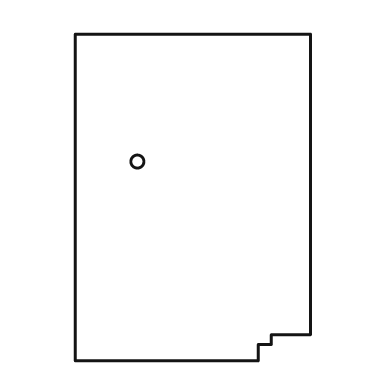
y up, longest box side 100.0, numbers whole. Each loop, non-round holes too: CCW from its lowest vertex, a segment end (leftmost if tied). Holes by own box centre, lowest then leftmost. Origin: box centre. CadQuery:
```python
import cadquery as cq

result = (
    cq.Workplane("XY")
    .moveTo(-36.0, -50.0)
    .lineTo(20.0, -50.0)
    .lineTo(20.0, -45.0)
    .lineTo(24.0, -45.0)
    .lineTo(24.0, -42.0)
    .lineTo(36.0, -42.0)
    .lineTo(36.0, 50.0)
    .lineTo(-36.0, 50.0)
    .close()
    .moveTo(-17.0, 11.0)
    .circle(2.0)
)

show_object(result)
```